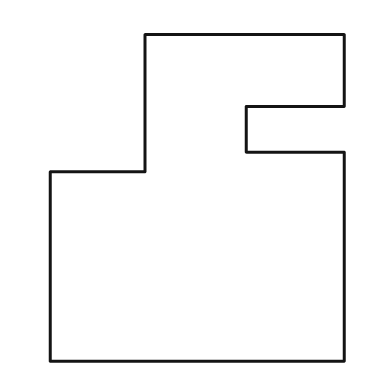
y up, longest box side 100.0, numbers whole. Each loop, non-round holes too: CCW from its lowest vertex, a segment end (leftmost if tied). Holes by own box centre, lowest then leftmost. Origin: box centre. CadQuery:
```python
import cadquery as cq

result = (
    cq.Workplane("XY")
    .moveTo(-45.0, -50.0)
    .lineTo(45.0, -50.0)
    .lineTo(45.0, 14.0)
    .lineTo(15.0, 14.0)
    .lineTo(15.0, 28.0)
    .lineTo(45.0, 28.0)
    .lineTo(45.0, 50.0)
    .lineTo(-16.0, 50.0)
    .lineTo(-16.0, 8.0)
    .lineTo(-45.0, 8.0)
    .close()
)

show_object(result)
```